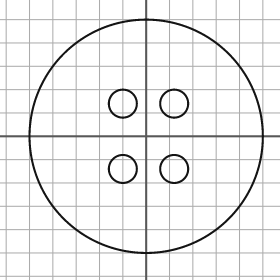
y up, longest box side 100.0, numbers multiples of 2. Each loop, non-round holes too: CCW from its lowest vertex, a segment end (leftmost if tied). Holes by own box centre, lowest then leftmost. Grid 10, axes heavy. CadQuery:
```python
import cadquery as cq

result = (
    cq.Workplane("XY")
    .moveTo(0.0, 0.0)
    .circle(50.0)
    .moveTo(-10.0, -14.0)
    .circle(6.0)
    .moveTo(12.0, -14.0)
    .circle(6.0)
    .moveTo(-10.0, 14.0)
    .circle(6.0)
    .moveTo(12.0, 14.0)
    .circle(6.0)
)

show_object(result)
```